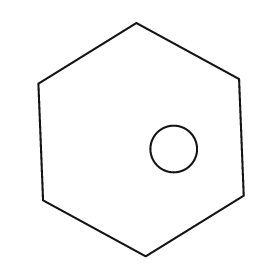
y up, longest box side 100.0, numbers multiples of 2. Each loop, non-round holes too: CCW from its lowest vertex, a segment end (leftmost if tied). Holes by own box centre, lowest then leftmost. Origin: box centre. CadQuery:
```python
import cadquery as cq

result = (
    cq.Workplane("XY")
    .moveTo(2.0, -50.0)
    .lineTo(44.0, -24.0)
    .lineTo(42.0, 26.0)
    .lineTo(-2.0, 50.0)
    .lineTo(-44.0, 24.0)
    .lineTo(-42.0, -26.0)
    .close()
    .moveTo(14.0, -4.0)
    .circle(10.0)
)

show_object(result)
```